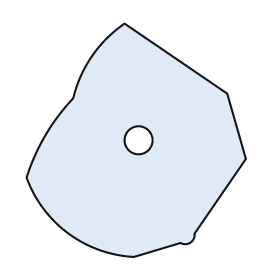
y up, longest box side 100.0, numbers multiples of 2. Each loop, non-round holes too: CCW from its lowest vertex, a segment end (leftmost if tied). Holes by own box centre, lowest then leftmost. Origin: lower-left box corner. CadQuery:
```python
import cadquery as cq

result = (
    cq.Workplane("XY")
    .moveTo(46.0, 0.0)
    .lineTo(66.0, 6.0)
    .threePointArc((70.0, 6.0), (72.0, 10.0))
    .lineTo(94.0, 42.0)
    .lineTo(86.0, 70.0)
    .lineTo(42.0, 100.0)
    .threePointArc((28.0, 86.0), (20.0, 68.0))
    .threePointArc((8.0, 52.0), (0.0, 34.0))
    .threePointArc((18.0, 10.0), (46.0, 0.0))
    .close()
    .moveTo(48.0, 50.0)
    .circle(6.0)
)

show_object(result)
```